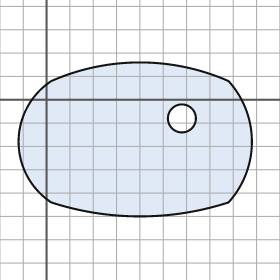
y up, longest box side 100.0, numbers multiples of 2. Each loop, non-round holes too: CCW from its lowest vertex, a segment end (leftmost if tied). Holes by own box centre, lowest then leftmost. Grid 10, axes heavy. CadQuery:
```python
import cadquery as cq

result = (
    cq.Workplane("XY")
    .moveTo(2.0, -44.0)
    .threePointArc((40.0, -50.0), (78.0, -44.0))
    .threePointArc((88.0, -18.0), (78.0, 8.0))
    .threePointArc((40.0, 16.0), (2.0, 8.0))
    .threePointArc((-12.0, -18.0), (2.0, -44.0))
    .close()
    .moveTo(58.0, -8.0)
    .circle(6.0)
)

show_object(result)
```